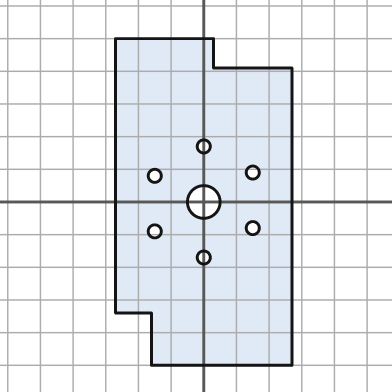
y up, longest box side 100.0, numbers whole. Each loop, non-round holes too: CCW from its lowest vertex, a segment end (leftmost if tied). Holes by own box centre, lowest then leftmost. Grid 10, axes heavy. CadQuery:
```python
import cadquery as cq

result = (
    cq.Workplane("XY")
    .moveTo(-16.0, -50.0)
    .lineTo(27.0, -50.0)
    .lineTo(27.0, 41.0)
    .lineTo(3.0, 41.0)
    .lineTo(3.0, 50.0)
    .lineTo(-27.0, 50.0)
    .lineTo(-27.0, -34.0)
    .lineTo(-16.0, -34.0)
    .close()
    .moveTo(0.0, -17.0)
    .circle(2.0)
    .moveTo(-15.0, -9.0)
    .circle(2.0)
    .moveTo(15.0, -8.0)
    .circle(2.0)
    .moveTo(0.0, 0.0)
    .circle(5.0)
    .moveTo(-15.0, 8.0)
    .circle(2.0)
    .moveTo(15.0, 9.0)
    .circle(2.0)
    .moveTo(0.0, 17.0)
    .circle(2.0)
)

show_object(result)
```